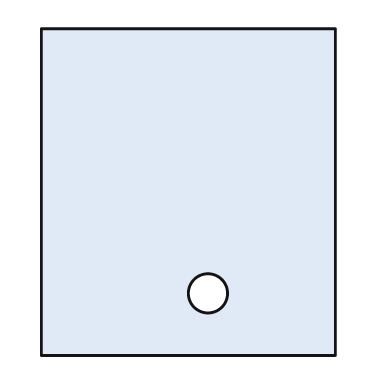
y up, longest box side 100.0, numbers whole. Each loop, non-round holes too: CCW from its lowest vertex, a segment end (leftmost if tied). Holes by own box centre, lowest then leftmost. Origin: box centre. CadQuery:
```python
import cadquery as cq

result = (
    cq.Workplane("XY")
    .moveTo(-45.0, -50.0)
    .lineTo(45.0, -50.0)
    .lineTo(45.0, 50.0)
    .lineTo(-45.0, 50.0)
    .close()
    .moveTo(6.0, -31.0)
    .circle(6.0)
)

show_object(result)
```